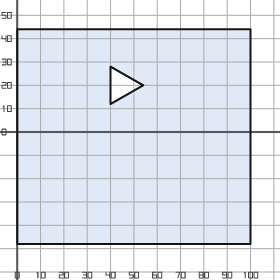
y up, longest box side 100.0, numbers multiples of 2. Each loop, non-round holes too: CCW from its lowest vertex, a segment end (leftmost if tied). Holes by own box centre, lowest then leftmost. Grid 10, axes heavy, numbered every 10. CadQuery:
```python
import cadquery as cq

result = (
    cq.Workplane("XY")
    .moveTo(0.0, -48.0)
    .lineTo(100.0, -48.0)
    .lineTo(100.0, 44.0)
    .lineTo(0.0, 44.0)
    .close()
    .moveTo(40.0, 12.0)
    .lineTo(54.0, 20.0)
    .lineTo(40.0, 28.0)
    .close()
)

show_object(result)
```